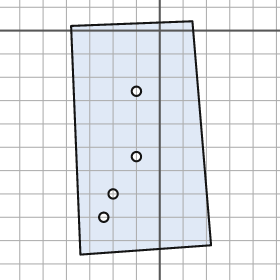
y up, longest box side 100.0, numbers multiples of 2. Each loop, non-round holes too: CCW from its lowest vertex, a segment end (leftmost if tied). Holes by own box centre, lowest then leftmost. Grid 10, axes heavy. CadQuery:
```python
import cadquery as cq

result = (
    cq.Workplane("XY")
    .moveTo(-34.0, -96.0)
    .lineTo(22.0, -92.0)
    .lineTo(14.0, 4.0)
    .lineTo(-38.0, 2.0)
    .close()
    .moveTo(-24.0, -80.0)
    .circle(2.0)
    .moveTo(-20.0, -70.0)
    .circle(2.0)
    .moveTo(-10.0, -54.0)
    .circle(2.0)
    .moveTo(-10.0, -26.0)
    .circle(2.0)
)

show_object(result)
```